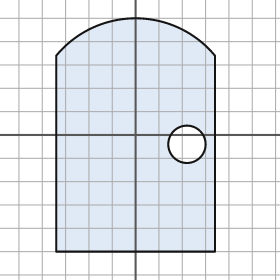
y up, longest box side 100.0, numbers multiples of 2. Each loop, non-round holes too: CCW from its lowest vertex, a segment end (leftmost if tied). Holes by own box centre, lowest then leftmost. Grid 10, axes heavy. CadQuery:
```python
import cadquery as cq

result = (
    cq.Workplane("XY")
    .moveTo(-34.0, -50.0)
    .lineTo(34.0, -50.0)
    .lineTo(34.0, 34.0)
    .threePointArc((0.0, 50.0), (-34.0, 34.0))
    .close()
    .moveTo(22.0, -4.0)
    .circle(8.0)
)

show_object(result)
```